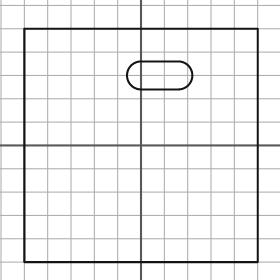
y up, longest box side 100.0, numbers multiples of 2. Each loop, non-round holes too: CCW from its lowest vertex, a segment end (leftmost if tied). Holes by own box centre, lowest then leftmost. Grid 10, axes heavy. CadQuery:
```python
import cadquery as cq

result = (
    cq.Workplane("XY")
    .moveTo(-50.0, -50.0)
    .lineTo(50.0, -50.0)
    .lineTo(50.0, 50.0)
    .lineTo(-50.0, 50.0)
    .close()
    .moveTo(0.0, 24.0)
    .lineTo(16.0, 24.0)
    .threePointArc((22.0, 30.0), (16.0, 36.0))
    .lineTo(0.0, 36.0)
    .threePointArc((-6.0, 30.0), (0.0, 24.0))
    .close()
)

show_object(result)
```